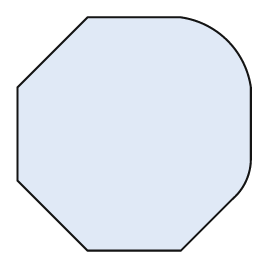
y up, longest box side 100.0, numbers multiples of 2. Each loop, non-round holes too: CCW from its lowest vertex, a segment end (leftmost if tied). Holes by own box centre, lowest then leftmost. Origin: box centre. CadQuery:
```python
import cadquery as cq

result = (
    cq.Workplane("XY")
    .moveTo(-20.0, -50.0)
    .lineTo(20.0, -50.0)
    .lineTo(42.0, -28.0)
    .threePointArc((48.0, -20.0), (50.0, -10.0))
    .lineTo(50.0, 20.0)
    .threePointArc((40.0, 40.0), (20.0, 50.0))
    .lineTo(-20.0, 50.0)
    .lineTo(-50.0, 20.0)
    .lineTo(-50.0, -20.0)
    .close()
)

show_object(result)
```